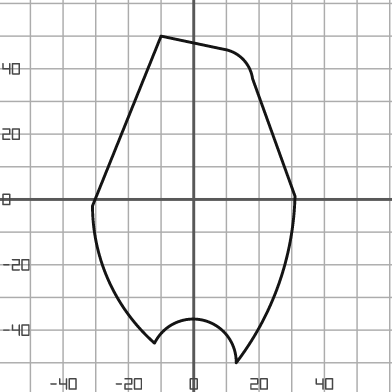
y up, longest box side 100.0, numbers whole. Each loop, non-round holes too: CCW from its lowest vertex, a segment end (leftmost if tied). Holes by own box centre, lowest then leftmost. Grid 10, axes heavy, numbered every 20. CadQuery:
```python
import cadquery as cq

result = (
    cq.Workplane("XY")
    .moveTo(13.0, -50.0)
    .threePointArc((26.0, -26.0), (31.0, 1.0))
    .lineTo(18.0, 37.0)
    .threePointArc((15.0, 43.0), (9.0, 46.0))
    .lineTo(-10.0, 50.0)
    .lineTo(-31.0, -2.0)
    .threePointArc((-26.0, -25.0), (-12.0, -44.0))
    .threePointArc((3.0, -37.0), (13.0, -50.0))
    .close()
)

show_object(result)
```